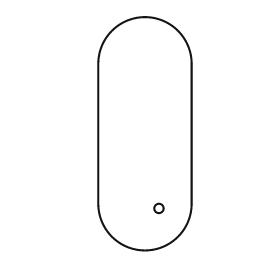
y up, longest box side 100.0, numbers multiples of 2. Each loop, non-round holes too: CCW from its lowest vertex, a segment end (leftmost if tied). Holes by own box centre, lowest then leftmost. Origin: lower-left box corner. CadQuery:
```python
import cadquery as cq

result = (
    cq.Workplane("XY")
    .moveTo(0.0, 20.0)
    .threePointArc((20.0, 0.0), (40.0, 20.0))
    .lineTo(40.0, 80.0)
    .threePointArc((20.0, 100.0), (0.0, 80.0))
    .close()
    .moveTo(26.0, 18.0)
    .circle(2.0)
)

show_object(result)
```